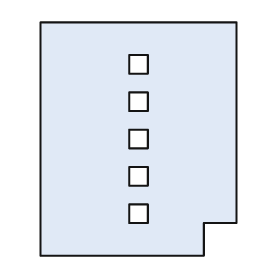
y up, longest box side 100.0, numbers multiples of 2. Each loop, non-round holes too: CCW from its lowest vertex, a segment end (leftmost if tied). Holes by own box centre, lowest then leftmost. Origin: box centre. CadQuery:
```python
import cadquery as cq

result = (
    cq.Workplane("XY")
    .moveTo(-42.0, -50.0)
    .lineTo(28.0, -50.0)
    .lineTo(28.0, -36.0)
    .lineTo(42.0, -36.0)
    .lineTo(42.0, 50.0)
    .lineTo(-42.0, 50.0)
    .close()
    .moveTo(-4.0, -36.0)
    .lineTo(4.0, -36.0)
    .lineTo(4.0, -28.0)
    .lineTo(-4.0, -28.0)
    .close()
    .moveTo(-4.0, -20.0)
    .lineTo(4.0, -20.0)
    .lineTo(4.0, -12.0)
    .lineTo(-4.0, -12.0)
    .close()
    .moveTo(-4.0, -4.0)
    .lineTo(4.0, -4.0)
    .lineTo(4.0, 4.0)
    .lineTo(-4.0, 4.0)
    .close()
    .moveTo(-4.0, 12.0)
    .lineTo(4.0, 12.0)
    .lineTo(4.0, 20.0)
    .lineTo(-4.0, 20.0)
    .close()
    .moveTo(-4.0, 28.0)
    .lineTo(4.0, 28.0)
    .lineTo(4.0, 36.0)
    .lineTo(-4.0, 36.0)
    .close()
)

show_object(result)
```